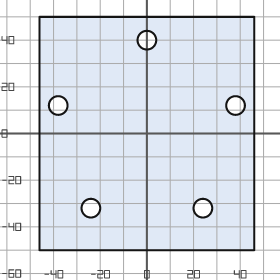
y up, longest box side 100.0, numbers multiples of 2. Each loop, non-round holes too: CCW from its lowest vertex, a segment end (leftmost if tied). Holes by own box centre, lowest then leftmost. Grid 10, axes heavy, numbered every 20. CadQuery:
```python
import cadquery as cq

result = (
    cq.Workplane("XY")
    .moveTo(-46.0, -50.0)
    .lineTo(46.0, -50.0)
    .lineTo(46.0, 50.0)
    .lineTo(-46.0, 50.0)
    .close()
    .moveTo(-24.0, -32.0)
    .circle(4.0)
    .moveTo(24.0, -32.0)
    .circle(4.0)
    .moveTo(-38.0, 12.0)
    .circle(4.0)
    .moveTo(38.0, 12.0)
    .circle(4.0)
    .moveTo(0.0, 40.0)
    .circle(4.0)
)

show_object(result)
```